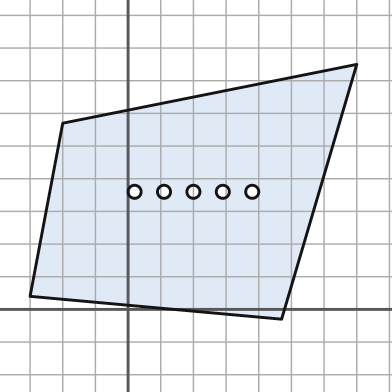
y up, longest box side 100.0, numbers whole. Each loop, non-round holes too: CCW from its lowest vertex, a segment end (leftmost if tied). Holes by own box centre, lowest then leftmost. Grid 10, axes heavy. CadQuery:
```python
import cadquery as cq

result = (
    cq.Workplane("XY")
    .moveTo(47.0, -3.0)
    .lineTo(70.0, 75.0)
    .lineTo(-20.0, 57.0)
    .lineTo(-30.0, 4.0)
    .close()
    .moveTo(2.0, 36.0)
    .circle(2.0)
    .moveTo(11.0, 36.0)
    .circle(2.0)
    .moveTo(20.0, 36.0)
    .circle(2.0)
    .moveTo(29.0, 36.0)
    .circle(2.0)
    .moveTo(38.0, 36.0)
    .circle(2.0)
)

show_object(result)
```